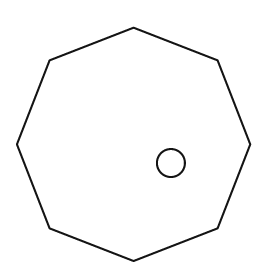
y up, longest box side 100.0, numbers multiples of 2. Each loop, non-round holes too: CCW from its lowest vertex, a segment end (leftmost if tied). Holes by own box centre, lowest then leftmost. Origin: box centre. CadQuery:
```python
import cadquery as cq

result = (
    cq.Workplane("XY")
    .moveTo(0.0, -50.0)
    .lineTo(36.0, -36.0)
    .lineTo(50.0, 0.0)
    .lineTo(36.0, 36.0)
    .lineTo(0.0, 50.0)
    .lineTo(-36.0, 36.0)
    .lineTo(-50.0, 0.0)
    .lineTo(-36.0, -36.0)
    .close()
    .moveTo(16.0, -8.0)
    .circle(6.0)
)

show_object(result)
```